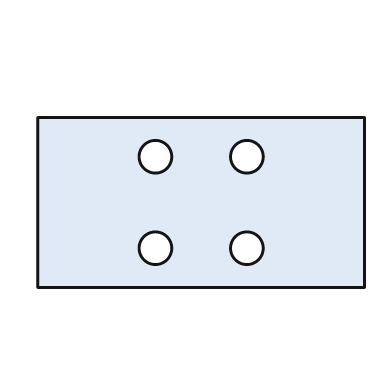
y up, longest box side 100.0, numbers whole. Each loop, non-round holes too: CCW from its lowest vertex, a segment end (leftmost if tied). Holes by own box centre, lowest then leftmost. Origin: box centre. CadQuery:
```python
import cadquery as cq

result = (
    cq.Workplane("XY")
    .moveTo(-50.0, -26.0)
    .lineTo(50.0, -26.0)
    .lineTo(50.0, 26.0)
    .lineTo(-50.0, 26.0)
    .close()
    .moveTo(-14.0, -14.0)
    .circle(5.0)
    .moveTo(14.0, -14.0)
    .circle(5.0)
    .moveTo(-14.0, 14.0)
    .circle(5.0)
    .moveTo(14.0, 14.0)
    .circle(5.0)
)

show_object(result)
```